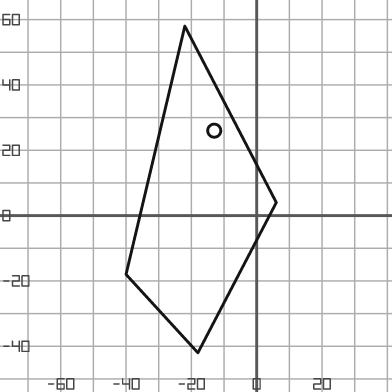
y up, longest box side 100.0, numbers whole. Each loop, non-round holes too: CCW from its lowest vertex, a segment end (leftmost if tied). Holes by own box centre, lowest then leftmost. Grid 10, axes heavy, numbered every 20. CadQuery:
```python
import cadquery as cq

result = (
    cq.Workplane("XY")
    .moveTo(-18.0, -42.0)
    .lineTo(6.0, 4.0)
    .lineTo(-22.0, 58.0)
    .lineTo(-40.0, -18.0)
    .close()
    .moveTo(-13.0, 26.0)
    .circle(2.0)
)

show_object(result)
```